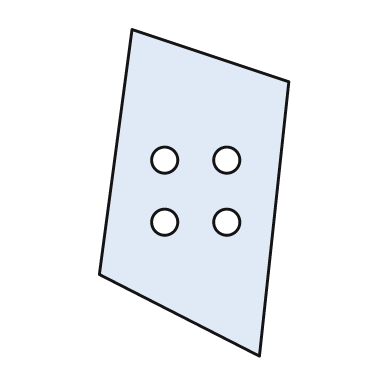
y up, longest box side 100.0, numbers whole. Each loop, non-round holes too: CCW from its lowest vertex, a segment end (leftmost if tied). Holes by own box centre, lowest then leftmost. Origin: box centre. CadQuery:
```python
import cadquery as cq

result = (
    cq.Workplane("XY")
    .moveTo(20.0, -50.0)
    .lineTo(29.0, 34.0)
    .lineTo(-19.0, 50.0)
    .lineTo(-29.0, -25.0)
    .close()
    .moveTo(-9.0, -9.0)
    .circle(4.0)
    .moveTo(10.0, -9.0)
    .circle(4.0)
    .moveTo(-9.0, 10.0)
    .circle(4.0)
    .moveTo(10.0, 10.0)
    .circle(4.0)
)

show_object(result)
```